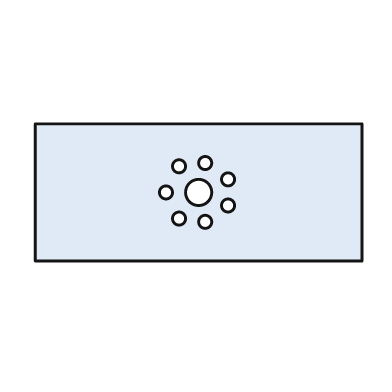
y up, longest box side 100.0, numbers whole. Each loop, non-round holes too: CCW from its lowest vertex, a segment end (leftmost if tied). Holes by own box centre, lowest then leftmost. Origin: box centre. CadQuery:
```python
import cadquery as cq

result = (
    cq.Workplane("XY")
    .moveTo(-50.0, -21.0)
    .lineTo(50.0, -21.0)
    .lineTo(50.0, 21.0)
    .lineTo(-50.0, 21.0)
    .close()
    .moveTo(2.0, -9.0)
    .circle(2.0)
    .moveTo(-6.0, -8.0)
    .circle(2.0)
    .moveTo(9.0, -4.0)
    .circle(2.0)
    .moveTo(-10.0, 0.0)
    .circle(2.0)
    .moveTo(0.0, 0.0)
    .circle(4.0)
    .moveTo(9.0, 4.0)
    .circle(2.0)
    .moveTo(-6.0, 8.0)
    .circle(2.0)
    .moveTo(2.0, 9.0)
    .circle(2.0)
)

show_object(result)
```